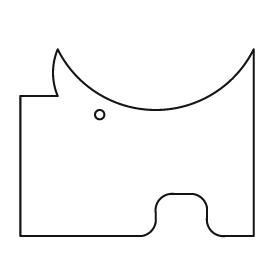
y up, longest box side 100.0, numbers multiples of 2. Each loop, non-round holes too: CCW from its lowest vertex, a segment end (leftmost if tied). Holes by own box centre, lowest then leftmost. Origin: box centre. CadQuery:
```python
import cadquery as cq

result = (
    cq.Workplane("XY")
    .moveTo(-50.0, -40.0)
    .lineTo(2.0, -40.0)
    .threePointArc((6.0, -38.0), (8.0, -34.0))
    .lineTo(8.0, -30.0)
    .threePointArc((10.0, -24.0), (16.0, -22.0))
    .lineTo(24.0, -22.0)
    .threePointArc((28.0, -24.0), (30.0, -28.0))
    .lineTo(30.0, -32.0)
    .threePointArc((32.0, -38.0), (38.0, -40.0))
    .lineTo(50.0, -40.0)
    .lineTo(50.0, 40.0)
    .threePointArc((8.0, 14.0), (-34.0, 40.0))
    .threePointArc((-36.0, 30.0), (-34.0, 20.0))
    .lineTo(-50.0, 20.0)
    .close()
    .moveTo(-16.0, 12.0)
    .circle(2.0)
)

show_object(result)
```